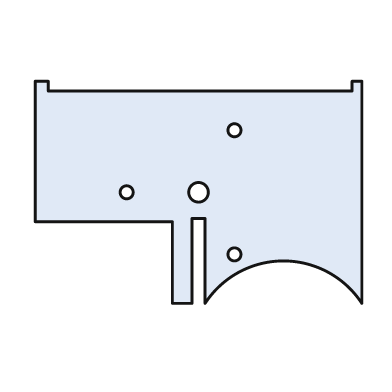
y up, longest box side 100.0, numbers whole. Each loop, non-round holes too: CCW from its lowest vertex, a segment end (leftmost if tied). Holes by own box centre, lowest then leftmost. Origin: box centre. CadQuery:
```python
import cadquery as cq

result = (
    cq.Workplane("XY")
    .moveTo(-8.0, -34.0)
    .lineTo(-2.0, -34.0)
    .lineTo(-2.0, -8.0)
    .lineTo(2.0, -8.0)
    .lineTo(2.0, -34.0)
    .threePointArc((26.0, -21.0), (50.0, -34.0))
    .lineTo(50.0, 34.0)
    .lineTo(47.0, 34.0)
    .lineTo(47.0, 31.0)
    .lineTo(-46.0, 31.0)
    .lineTo(-46.0, 34.0)
    .lineTo(-50.0, 34.0)
    .lineTo(-50.0, -9.0)
    .lineTo(-8.0, -9.0)
    .close()
    .moveTo(11.0, -19.0)
    .circle(2.0)
    .moveTo(-22.0, 0.0)
    .circle(2.0)
    .moveTo(0.0, 0.0)
    .circle(3.0)
    .moveTo(11.0, 19.0)
    .circle(2.0)
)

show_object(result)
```